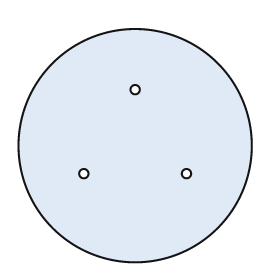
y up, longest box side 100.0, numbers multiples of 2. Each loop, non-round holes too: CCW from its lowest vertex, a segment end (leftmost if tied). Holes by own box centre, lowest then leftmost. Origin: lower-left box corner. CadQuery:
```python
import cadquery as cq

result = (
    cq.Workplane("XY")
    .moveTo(50.0, 50.0)
    .circle(50.0)
    .moveTo(28.0, 38.0)
    .circle(2.0)
    .moveTo(72.0, 38.0)
    .circle(2.0)
    .moveTo(50.0, 74.0)
    .circle(2.0)
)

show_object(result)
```